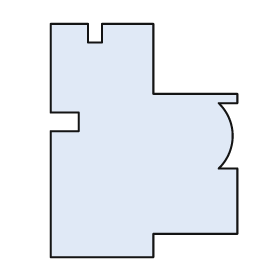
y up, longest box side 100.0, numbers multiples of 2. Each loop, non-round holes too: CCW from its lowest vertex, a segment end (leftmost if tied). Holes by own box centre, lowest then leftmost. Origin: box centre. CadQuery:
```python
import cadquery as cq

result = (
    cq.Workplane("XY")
    .moveTo(-40.0, -50.0)
    .lineTo(4.0, -50.0)
    .lineTo(4.0, -40.0)
    .lineTo(40.0, -40.0)
    .lineTo(40.0, -12.0)
    .lineTo(32.0, -12.0)
    .threePointArc((38.0, 2.0), (32.0, 16.0))
    .lineTo(40.0, 16.0)
    .lineTo(40.0, 20.0)
    .lineTo(4.0, 20.0)
    .lineTo(4.0, 50.0)
    .lineTo(-18.0, 50.0)
    .lineTo(-18.0, 42.0)
    .lineTo(-24.0, 42.0)
    .lineTo(-24.0, 50.0)
    .lineTo(-40.0, 50.0)
    .lineTo(-40.0, 12.0)
    .lineTo(-28.0, 12.0)
    .lineTo(-28.0, 4.0)
    .lineTo(-40.0, 4.0)
    .close()
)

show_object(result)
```